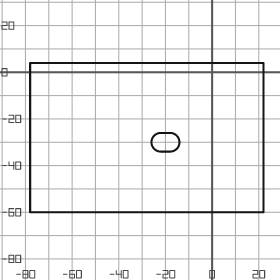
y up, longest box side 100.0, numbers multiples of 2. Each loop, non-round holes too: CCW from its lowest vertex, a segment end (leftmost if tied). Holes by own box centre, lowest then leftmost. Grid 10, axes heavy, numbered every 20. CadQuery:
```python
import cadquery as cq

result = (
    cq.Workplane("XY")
    .moveTo(-78.0, -60.0)
    .lineTo(22.0, -60.0)
    .lineTo(22.0, 4.0)
    .lineTo(-78.0, 4.0)
    .close()
    .moveTo(-22.0, -34.0)
    .lineTo(-18.0, -34.0)
    .threePointArc((-14.0, -30.0), (-18.0, -26.0))
    .lineTo(-22.0, -26.0)
    .threePointArc((-26.0, -30.0), (-22.0, -34.0))
    .close()
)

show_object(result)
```